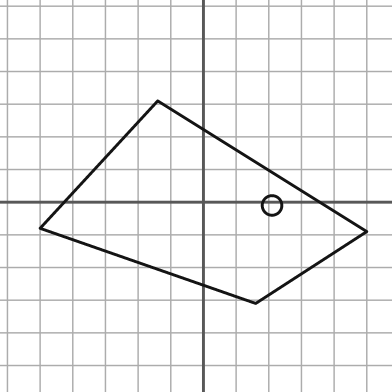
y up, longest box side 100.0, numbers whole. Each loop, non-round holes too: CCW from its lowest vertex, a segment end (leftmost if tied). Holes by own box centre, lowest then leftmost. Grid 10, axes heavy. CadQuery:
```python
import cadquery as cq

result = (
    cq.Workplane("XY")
    .moveTo(16.0, -31.0)
    .lineTo(50.0, -9.0)
    .lineTo(-14.0, 31.0)
    .lineTo(-50.0, -8.0)
    .close()
    .moveTo(21.0, -1.0)
    .circle(3.0)
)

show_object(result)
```